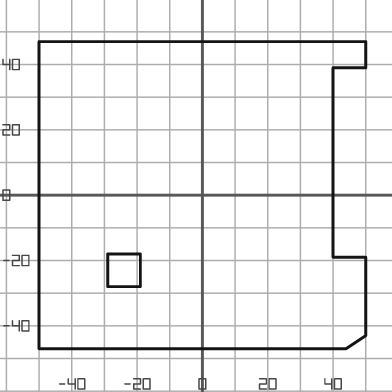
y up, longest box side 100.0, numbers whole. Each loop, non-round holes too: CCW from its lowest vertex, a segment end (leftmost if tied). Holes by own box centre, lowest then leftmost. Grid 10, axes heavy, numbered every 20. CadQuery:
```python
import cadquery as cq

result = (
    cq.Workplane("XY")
    .moveTo(-50.0, -47.0)
    .lineTo(44.0, -47.0)
    .lineTo(50.0, -43.0)
    .lineTo(50.0, -19.0)
    .lineTo(40.0, -19.0)
    .lineTo(40.0, 39.0)
    .lineTo(50.0, 39.0)
    .lineTo(50.0, 47.0)
    .lineTo(-50.0, 47.0)
    .close()
    .moveTo(-29.0, -28.0)
    .lineTo(-19.0, -28.0)
    .lineTo(-19.0, -18.0)
    .lineTo(-29.0, -18.0)
    .close()
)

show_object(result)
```